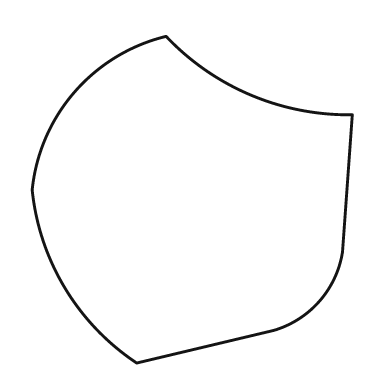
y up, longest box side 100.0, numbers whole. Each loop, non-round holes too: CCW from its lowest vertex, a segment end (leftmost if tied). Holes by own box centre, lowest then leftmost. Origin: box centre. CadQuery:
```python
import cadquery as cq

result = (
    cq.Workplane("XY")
    .moveTo(-17.0, -50.0)
    .lineTo(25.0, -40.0)
    .threePointArc((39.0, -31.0), (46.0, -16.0))
    .lineTo(49.0, 26.0)
    .threePointArc((18.0, 32.0), (-8.0, 50.0))
    .threePointArc((-36.0, 33.0), (-49.0, 3.0))
    .threePointArc((-39.0, -27.0), (-17.0, -50.0))
    .close()
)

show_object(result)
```